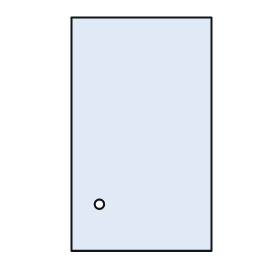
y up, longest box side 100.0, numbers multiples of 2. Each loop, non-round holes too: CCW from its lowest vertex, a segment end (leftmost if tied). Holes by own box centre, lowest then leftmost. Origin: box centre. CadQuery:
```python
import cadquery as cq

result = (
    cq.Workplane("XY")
    .moveTo(-30.0, -50.0)
    .lineTo(30.0, -50.0)
    .lineTo(30.0, 50.0)
    .lineTo(-30.0, 50.0)
    .close()
    .moveTo(-18.0, -30.0)
    .circle(2.0)
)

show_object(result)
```